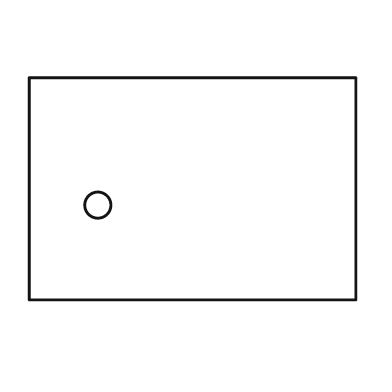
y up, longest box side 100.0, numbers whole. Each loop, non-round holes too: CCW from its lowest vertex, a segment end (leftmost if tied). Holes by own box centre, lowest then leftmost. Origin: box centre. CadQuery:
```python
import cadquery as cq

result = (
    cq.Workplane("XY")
    .moveTo(-50.0, -34.0)
    .lineTo(50.0, -34.0)
    .lineTo(50.0, 34.0)
    .lineTo(-50.0, 34.0)
    .close()
    .moveTo(-29.0, -5.0)
    .circle(4.0)
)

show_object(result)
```